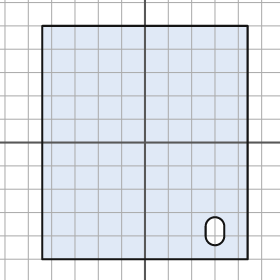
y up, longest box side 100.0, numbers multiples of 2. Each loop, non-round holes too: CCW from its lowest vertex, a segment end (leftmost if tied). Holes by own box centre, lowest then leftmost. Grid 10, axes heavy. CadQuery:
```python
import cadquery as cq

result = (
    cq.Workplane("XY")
    .moveTo(-44.0, -50.0)
    .lineTo(44.0, -50.0)
    .lineTo(44.0, 50.0)
    .lineTo(-44.0, 50.0)
    .close()
    .moveTo(26.0, -40.0)
    .threePointArc((30.0, -44.0), (34.0, -40.0))
    .lineTo(34.0, -36.0)
    .threePointArc((30.0, -32.0), (26.0, -36.0))
    .close()
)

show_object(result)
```